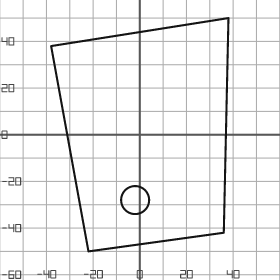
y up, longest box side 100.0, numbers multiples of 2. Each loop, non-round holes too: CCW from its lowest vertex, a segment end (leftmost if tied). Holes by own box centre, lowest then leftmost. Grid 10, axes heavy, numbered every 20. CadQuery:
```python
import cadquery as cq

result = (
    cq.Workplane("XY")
    .moveTo(-22.0, -50.0)
    .lineTo(36.0, -42.0)
    .lineTo(38.0, 50.0)
    .lineTo(-38.0, 38.0)
    .close()
    .moveTo(-2.0, -28.0)
    .circle(6.0)
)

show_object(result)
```